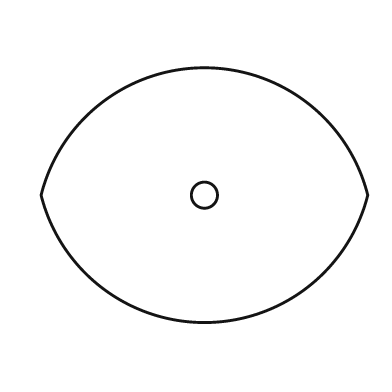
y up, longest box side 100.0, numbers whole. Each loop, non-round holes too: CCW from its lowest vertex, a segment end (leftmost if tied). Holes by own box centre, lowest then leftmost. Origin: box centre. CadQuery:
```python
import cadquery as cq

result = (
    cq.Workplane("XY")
    .moveTo(-50.0, 0.0)
    .threePointArc((0.0, -39.0), (50.0, 0.0))
    .threePointArc((0.0, 39.0), (-50.0, 0.0))
    .close()
    .moveTo(0.0, 0.0)
    .circle(4.0)
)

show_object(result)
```